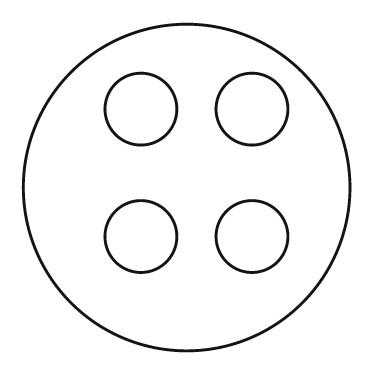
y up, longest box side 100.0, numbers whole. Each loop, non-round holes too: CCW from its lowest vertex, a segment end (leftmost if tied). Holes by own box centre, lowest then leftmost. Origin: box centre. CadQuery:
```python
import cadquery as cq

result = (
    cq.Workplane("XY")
    .moveTo(0.0, 0.0)
    .circle(50.0)
    .moveTo(-14.0, -15.0)
    .circle(11.0)
    .moveTo(20.0, -15.0)
    .circle(11.0)
    .moveTo(-14.0, 24.0)
    .circle(11.0)
    .moveTo(20.0, 24.0)
    .circle(11.0)
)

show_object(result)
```